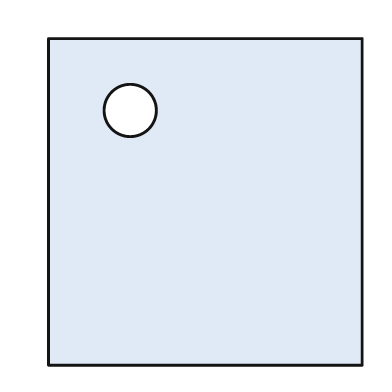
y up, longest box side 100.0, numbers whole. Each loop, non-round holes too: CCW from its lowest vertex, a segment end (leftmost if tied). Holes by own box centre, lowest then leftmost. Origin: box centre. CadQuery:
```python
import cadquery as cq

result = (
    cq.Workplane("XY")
    .moveTo(-48.0, -50.0)
    .lineTo(48.0, -50.0)
    .lineTo(48.0, 50.0)
    .lineTo(-48.0, 50.0)
    .close()
    .moveTo(-23.0, 28.0)
    .circle(8.0)
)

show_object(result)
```